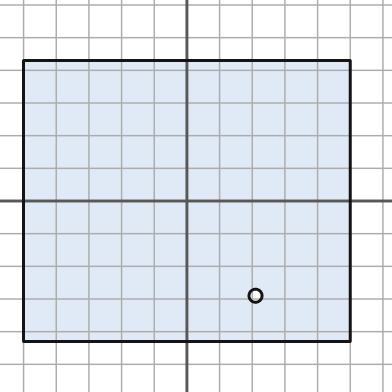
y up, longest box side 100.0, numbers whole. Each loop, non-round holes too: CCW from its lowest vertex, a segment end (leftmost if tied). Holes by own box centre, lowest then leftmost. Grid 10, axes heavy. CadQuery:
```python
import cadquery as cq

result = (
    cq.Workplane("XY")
    .moveTo(-50.0, -43.0)
    .lineTo(50.0, -43.0)
    .lineTo(50.0, 43.0)
    .lineTo(-50.0, 43.0)
    .close()
    .moveTo(21.0, -29.0)
    .circle(2.0)
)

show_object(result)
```